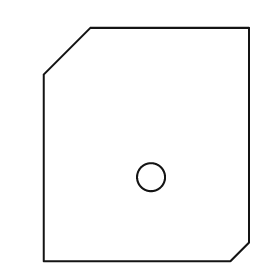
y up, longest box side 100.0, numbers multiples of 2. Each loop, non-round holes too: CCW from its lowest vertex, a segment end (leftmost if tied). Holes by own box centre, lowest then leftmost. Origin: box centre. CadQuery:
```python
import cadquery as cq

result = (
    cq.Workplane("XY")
    .moveTo(-44.0, -50.0)
    .lineTo(36.0, -50.0)
    .lineTo(44.0, -42.0)
    .lineTo(44.0, 50.0)
    .lineTo(-24.0, 50.0)
    .lineTo(-44.0, 30.0)
    .close()
    .moveTo(2.0, -14.0)
    .circle(6.0)
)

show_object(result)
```